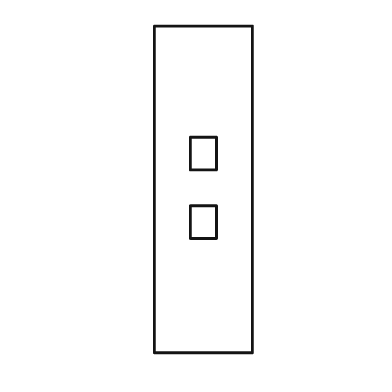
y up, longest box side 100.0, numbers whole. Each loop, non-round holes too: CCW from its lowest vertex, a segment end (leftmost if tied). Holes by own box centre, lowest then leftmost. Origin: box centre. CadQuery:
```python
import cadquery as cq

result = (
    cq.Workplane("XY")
    .moveTo(-15.0, -50.0)
    .lineTo(15.0, -50.0)
    .lineTo(15.0, 50.0)
    .lineTo(-15.0, 50.0)
    .close()
    .moveTo(-4.0, -15.0)
    .lineTo(4.0, -15.0)
    .lineTo(4.0, -5.0)
    .lineTo(-4.0, -5.0)
    .close()
    .moveTo(-4.0, 6.0)
    .lineTo(4.0, 6.0)
    .lineTo(4.0, 16.0)
    .lineTo(-4.0, 16.0)
    .close()
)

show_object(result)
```